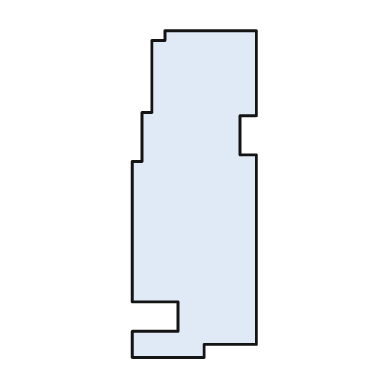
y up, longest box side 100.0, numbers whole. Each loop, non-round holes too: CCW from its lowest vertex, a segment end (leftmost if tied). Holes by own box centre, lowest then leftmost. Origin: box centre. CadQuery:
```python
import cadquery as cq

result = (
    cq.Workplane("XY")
    .moveTo(-19.0, -50.0)
    .lineTo(3.0, -50.0)
    .lineTo(3.0, -46.0)
    .lineTo(19.0, -46.0)
    .lineTo(19.0, 12.0)
    .lineTo(14.0, 12.0)
    .lineTo(14.0, 24.0)
    .lineTo(19.0, 24.0)
    .lineTo(19.0, 50.0)
    .lineTo(-9.0, 50.0)
    .lineTo(-9.0, 47.0)
    .lineTo(-13.0, 47.0)
    .lineTo(-13.0, 25.0)
    .lineTo(-16.0, 25.0)
    .lineTo(-16.0, 10.0)
    .lineTo(-19.0, 10.0)
    .lineTo(-19.0, -33.0)
    .lineTo(-5.0, -33.0)
    .lineTo(-5.0, -42.0)
    .lineTo(-19.0, -42.0)
    .close()
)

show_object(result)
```